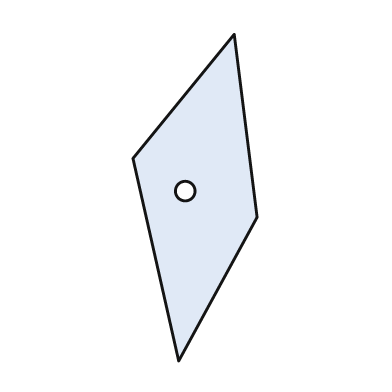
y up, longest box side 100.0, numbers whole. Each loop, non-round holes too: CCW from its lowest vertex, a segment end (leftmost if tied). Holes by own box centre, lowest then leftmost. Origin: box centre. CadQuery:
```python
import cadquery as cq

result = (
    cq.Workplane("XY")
    .moveTo(-5.0, -50.0)
    .lineTo(19.0, -6.0)
    .lineTo(12.0, 50.0)
    .lineTo(-19.0, 12.0)
    .close()
    .moveTo(-3.0, 2.0)
    .circle(3.0)
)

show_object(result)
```